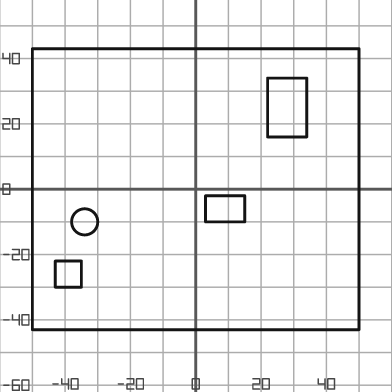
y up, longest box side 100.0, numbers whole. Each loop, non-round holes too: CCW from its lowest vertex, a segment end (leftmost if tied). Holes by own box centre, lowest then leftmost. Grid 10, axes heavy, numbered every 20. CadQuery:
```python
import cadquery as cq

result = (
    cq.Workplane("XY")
    .moveTo(-50.0, -43.0)
    .lineTo(50.0, -43.0)
    .lineTo(50.0, 43.0)
    .lineTo(-50.0, 43.0)
    .close()
    .moveTo(-43.0, -30.0)
    .lineTo(-35.0, -30.0)
    .lineTo(-35.0, -22.0)
    .lineTo(-43.0, -22.0)
    .close()
    .moveTo(-34.0, -10.0)
    .circle(4.0)
    .moveTo(3.0, -10.0)
    .lineTo(15.0, -10.0)
    .lineTo(15.0, -2.0)
    .lineTo(3.0, -2.0)
    .close()
    .moveTo(22.0, 16.0)
    .lineTo(34.0, 16.0)
    .lineTo(34.0, 34.0)
    .lineTo(22.0, 34.0)
    .close()
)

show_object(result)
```